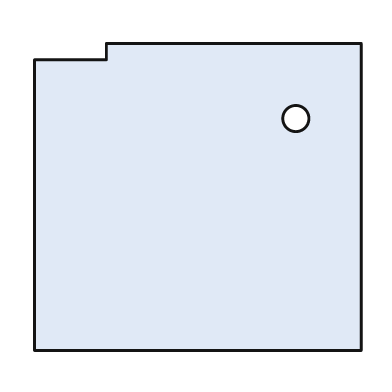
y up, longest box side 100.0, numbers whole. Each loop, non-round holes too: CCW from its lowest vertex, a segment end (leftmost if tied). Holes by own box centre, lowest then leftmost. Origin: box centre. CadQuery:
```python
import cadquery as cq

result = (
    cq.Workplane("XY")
    .moveTo(-50.0, -47.0)
    .lineTo(50.0, -47.0)
    .lineTo(50.0, 47.0)
    .lineTo(-28.0, 47.0)
    .lineTo(-28.0, 42.0)
    .lineTo(-50.0, 42.0)
    .close()
    .moveTo(30.0, 24.0)
    .circle(4.0)
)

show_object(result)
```